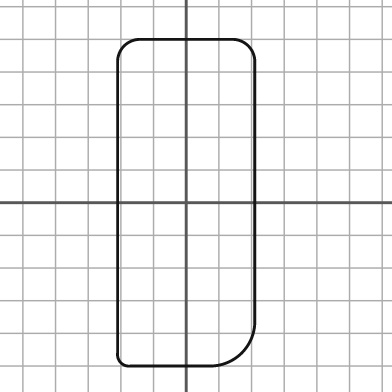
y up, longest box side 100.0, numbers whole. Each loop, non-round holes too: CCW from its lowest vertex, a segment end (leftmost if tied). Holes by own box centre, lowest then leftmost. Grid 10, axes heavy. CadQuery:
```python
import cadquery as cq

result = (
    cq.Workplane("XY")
    .moveTo(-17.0, -50.0)
    .lineTo(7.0, -50.0)
    .threePointArc((17.0, -46.0), (21.0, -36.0))
    .lineTo(21.0, 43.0)
    .threePointArc((19.0, 48.0), (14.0, 50.0))
    .lineTo(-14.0, 50.0)
    .threePointArc((-19.0, 48.0), (-21.0, 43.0))
    .lineTo(-21.0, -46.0)
    .threePointArc((-20.0, -49.0), (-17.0, -50.0))
    .close()
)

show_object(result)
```